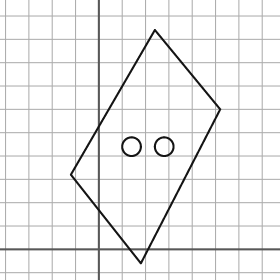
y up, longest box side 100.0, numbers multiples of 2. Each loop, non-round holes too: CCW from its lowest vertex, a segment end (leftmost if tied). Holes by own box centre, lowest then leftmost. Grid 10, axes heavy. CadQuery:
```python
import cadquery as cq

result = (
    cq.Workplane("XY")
    .moveTo(18.0, -6.0)
    .lineTo(52.0, 60.0)
    .lineTo(24.0, 94.0)
    .lineTo(-12.0, 32.0)
    .close()
    .moveTo(14.0, 44.0)
    .circle(4.0)
    .moveTo(28.0, 44.0)
    .circle(4.0)
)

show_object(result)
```